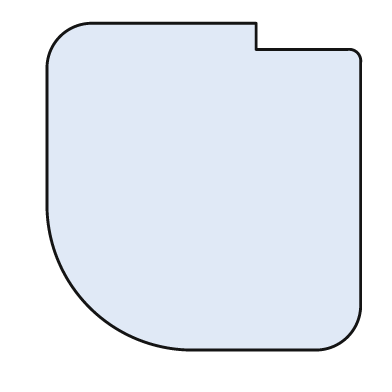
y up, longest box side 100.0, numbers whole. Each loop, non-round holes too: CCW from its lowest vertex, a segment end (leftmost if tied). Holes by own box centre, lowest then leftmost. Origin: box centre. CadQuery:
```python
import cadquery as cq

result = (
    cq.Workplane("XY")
    .moveTo(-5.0, -50.0)
    .lineTo(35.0, -50.0)
    .threePointArc((44.0, -46.0), (48.0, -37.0))
    .lineTo(48.0, 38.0)
    .threePointArc((47.0, 41.0), (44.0, 42.0))
    .lineTo(16.0, 42.0)
    .lineTo(16.0, 50.0)
    .lineTo(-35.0, 50.0)
    .threePointArc((-44.0, 46.0), (-48.0, 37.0))
    .lineTo(-48.0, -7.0)
    .threePointArc((-35.0, -37.0), (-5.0, -50.0))
    .close()
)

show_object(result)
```